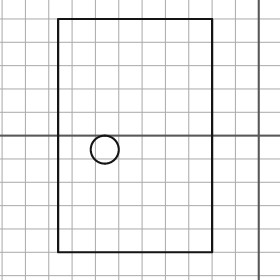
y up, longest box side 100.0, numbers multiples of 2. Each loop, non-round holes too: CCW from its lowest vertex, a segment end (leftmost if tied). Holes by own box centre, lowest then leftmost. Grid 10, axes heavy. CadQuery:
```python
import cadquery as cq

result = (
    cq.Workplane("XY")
    .moveTo(-86.0, -50.0)
    .lineTo(-20.0, -50.0)
    .lineTo(-20.0, 50.0)
    .lineTo(-86.0, 50.0)
    .close()
    .moveTo(-66.0, -6.0)
    .circle(6.0)
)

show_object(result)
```